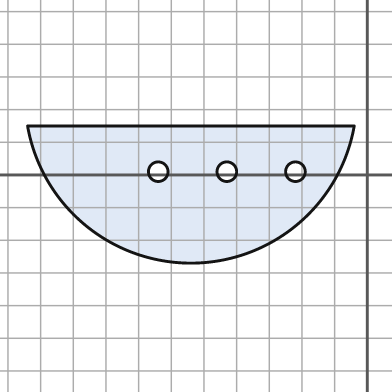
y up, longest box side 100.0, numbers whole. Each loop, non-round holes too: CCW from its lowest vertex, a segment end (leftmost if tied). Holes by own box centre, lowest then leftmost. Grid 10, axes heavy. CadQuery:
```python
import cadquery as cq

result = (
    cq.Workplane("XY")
    .moveTo(-104.0, 15.0)
    .threePointArc((-54.0, -27.0), (-4.0, 15.0))
    .close()
    .moveTo(-64.0, 1.0)
    .circle(3.0)
    .moveTo(-43.0, 1.0)
    .circle(3.0)
    .moveTo(-22.0, 1.0)
    .circle(3.0)
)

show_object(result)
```